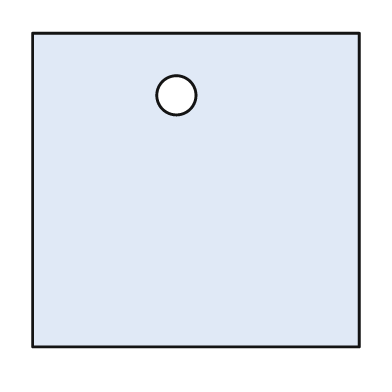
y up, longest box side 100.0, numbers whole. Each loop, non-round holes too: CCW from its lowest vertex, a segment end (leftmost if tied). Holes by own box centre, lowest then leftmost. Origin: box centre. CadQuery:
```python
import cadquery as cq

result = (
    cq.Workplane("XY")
    .moveTo(-50.0, -48.0)
    .lineTo(50.0, -48.0)
    .lineTo(50.0, 48.0)
    .lineTo(-50.0, 48.0)
    .close()
    .moveTo(-6.0, 29.0)
    .circle(6.0)
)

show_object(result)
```